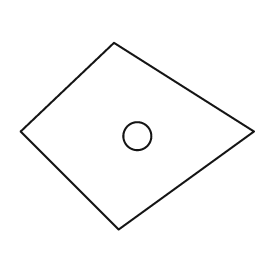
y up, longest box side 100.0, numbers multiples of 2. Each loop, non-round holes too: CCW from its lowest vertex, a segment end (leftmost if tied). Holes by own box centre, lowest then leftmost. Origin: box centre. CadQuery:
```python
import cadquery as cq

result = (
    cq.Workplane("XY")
    .moveTo(-8.0, -40.0)
    .lineTo(50.0, 2.0)
    .lineTo(-10.0, 40.0)
    .lineTo(-50.0, 2.0)
    .close()
    .moveTo(0.0, 0.0)
    .circle(6.0)
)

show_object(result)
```